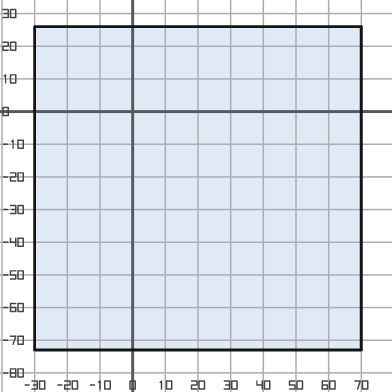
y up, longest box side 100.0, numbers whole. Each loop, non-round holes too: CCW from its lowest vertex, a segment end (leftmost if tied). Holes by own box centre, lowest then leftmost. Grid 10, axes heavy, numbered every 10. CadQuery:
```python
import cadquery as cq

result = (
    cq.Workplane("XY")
    .moveTo(-30.0, -73.0)
    .lineTo(70.0, -73.0)
    .lineTo(70.0, 26.0)
    .lineTo(-30.0, 26.0)
    .close()
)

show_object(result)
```